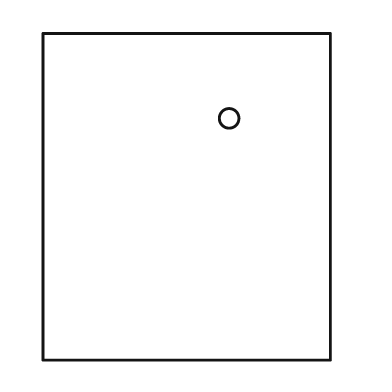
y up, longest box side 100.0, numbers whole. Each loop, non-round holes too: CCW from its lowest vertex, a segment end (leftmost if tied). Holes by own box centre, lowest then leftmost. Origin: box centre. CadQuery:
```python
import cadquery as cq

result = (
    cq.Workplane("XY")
    .moveTo(-44.0, -50.0)
    .lineTo(44.0, -50.0)
    .lineTo(44.0, 50.0)
    .lineTo(-44.0, 50.0)
    .close()
    .moveTo(13.0, 24.0)
    .circle(3.0)
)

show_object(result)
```